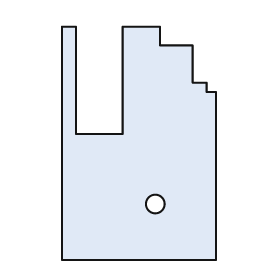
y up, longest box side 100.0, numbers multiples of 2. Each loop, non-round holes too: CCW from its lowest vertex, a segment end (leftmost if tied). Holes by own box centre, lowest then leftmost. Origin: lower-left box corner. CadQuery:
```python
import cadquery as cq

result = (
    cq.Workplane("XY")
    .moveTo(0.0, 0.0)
    .lineTo(66.0, 0.0)
    .lineTo(66.0, 72.0)
    .lineTo(62.0, 72.0)
    .lineTo(62.0, 76.0)
    .lineTo(56.0, 76.0)
    .lineTo(56.0, 92.0)
    .lineTo(42.0, 92.0)
    .lineTo(42.0, 100.0)
    .lineTo(26.0, 100.0)
    .lineTo(26.0, 54.0)
    .lineTo(6.0, 54.0)
    .lineTo(6.0, 100.0)
    .lineTo(0.0, 100.0)
    .close()
    .moveTo(40.0, 24.0)
    .circle(4.0)
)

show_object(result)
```